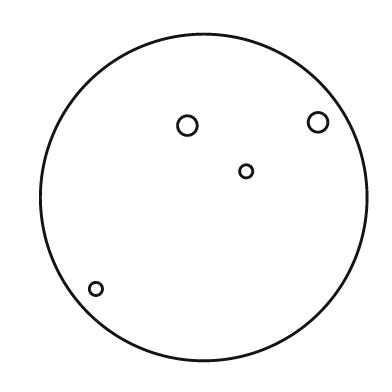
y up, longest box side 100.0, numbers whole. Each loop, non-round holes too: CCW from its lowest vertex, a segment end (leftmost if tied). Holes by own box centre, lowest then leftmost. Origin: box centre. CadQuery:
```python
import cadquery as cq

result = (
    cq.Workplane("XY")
    .moveTo(0.0, 0.0)
    .circle(50.0)
    .moveTo(-33.0, -28.0)
    .circle(2.0)
    .moveTo(13.0, 8.0)
    .circle(2.0)
    .moveTo(-5.0, 22.0)
    .circle(3.0)
    .moveTo(35.0, 23.0)
    .circle(3.0)
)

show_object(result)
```